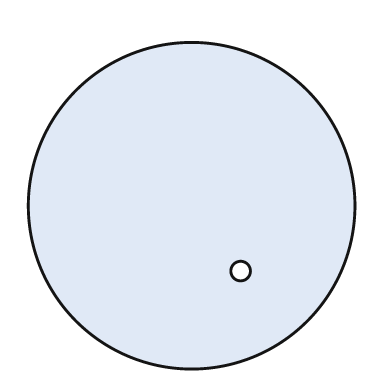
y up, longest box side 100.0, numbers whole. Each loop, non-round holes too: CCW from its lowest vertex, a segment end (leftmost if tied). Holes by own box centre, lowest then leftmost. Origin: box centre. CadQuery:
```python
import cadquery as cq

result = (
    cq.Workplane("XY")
    .moveTo(0.0, 0.0)
    .circle(50.0)
    .moveTo(15.0, -20.0)
    .circle(3.0)
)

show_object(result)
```